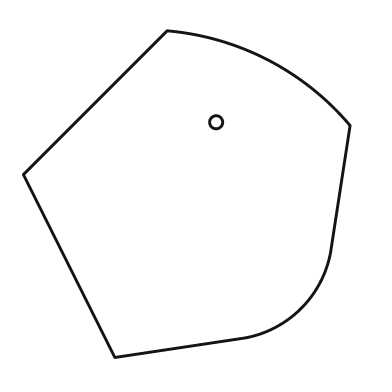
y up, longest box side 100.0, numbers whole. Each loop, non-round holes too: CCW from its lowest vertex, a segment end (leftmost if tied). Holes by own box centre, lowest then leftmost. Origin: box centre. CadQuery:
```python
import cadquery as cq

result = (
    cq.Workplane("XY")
    .moveTo(-22.0, -50.0)
    .lineTo(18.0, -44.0)
    .threePointArc((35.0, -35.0), (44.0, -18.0))
    .lineTo(50.0, 21.0)
    .threePointArc((25.0, 41.0), (-6.0, 50.0))
    .lineTo(-50.0, 6.0)
    .close()
    .moveTo(9.0, 22.0)
    .circle(2.0)
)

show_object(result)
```